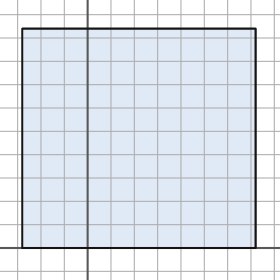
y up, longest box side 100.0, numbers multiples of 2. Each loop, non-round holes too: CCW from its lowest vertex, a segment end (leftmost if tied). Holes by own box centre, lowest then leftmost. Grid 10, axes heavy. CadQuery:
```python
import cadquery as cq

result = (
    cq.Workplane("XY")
    .moveTo(-28.0, 0.0)
    .lineTo(72.0, 0.0)
    .lineTo(72.0, 94.0)
    .lineTo(-28.0, 94.0)
    .close()
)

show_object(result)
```